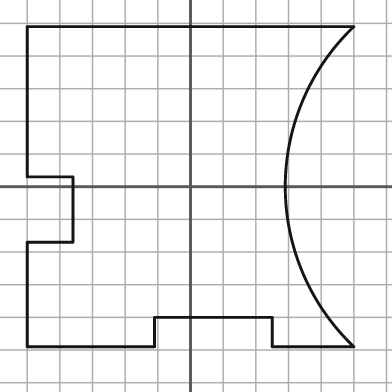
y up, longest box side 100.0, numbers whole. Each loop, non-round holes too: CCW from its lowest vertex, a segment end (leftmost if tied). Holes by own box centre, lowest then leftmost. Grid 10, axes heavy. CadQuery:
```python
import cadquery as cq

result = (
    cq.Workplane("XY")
    .moveTo(-50.0, -49.0)
    .lineTo(-11.0, -49.0)
    .lineTo(-11.0, -40.0)
    .lineTo(25.0, -40.0)
    .lineTo(25.0, -49.0)
    .lineTo(50.0, -49.0)
    .threePointArc((29.0, 0.0), (50.0, 49.0))
    .lineTo(-50.0, 49.0)
    .lineTo(-50.0, 3.0)
    .lineTo(-36.0, 3.0)
    .lineTo(-36.0, -17.0)
    .lineTo(-50.0, -17.0)
    .close()
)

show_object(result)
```